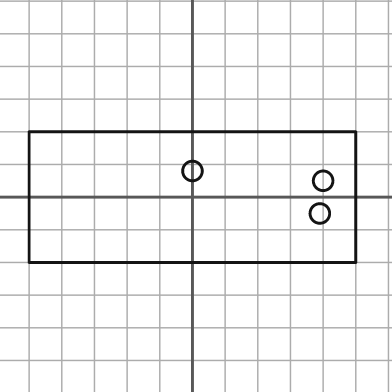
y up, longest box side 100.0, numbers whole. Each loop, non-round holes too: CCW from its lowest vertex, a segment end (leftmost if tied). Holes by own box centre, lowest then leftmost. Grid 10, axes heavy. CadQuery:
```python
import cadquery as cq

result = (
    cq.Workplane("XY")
    .moveTo(-50.0, -20.0)
    .lineTo(50.0, -20.0)
    .lineTo(50.0, 20.0)
    .lineTo(-50.0, 20.0)
    .close()
    .moveTo(39.0, -5.0)
    .circle(3.0)
    .moveTo(40.0, 5.0)
    .circle(3.0)
    .moveTo(0.0, 8.0)
    .circle(3.0)
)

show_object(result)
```